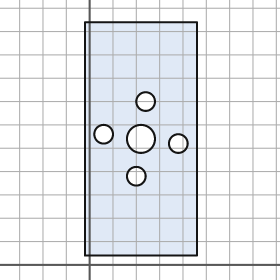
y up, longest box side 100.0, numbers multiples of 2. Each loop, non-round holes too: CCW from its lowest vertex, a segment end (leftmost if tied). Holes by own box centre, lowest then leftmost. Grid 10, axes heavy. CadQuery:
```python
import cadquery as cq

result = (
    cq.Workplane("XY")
    .moveTo(-2.0, 4.0)
    .lineTo(46.0, 4.0)
    .lineTo(46.0, 104.0)
    .lineTo(-2.0, 104.0)
    .close()
    .moveTo(20.0, 38.0)
    .circle(4.0)
    .moveTo(38.0, 52.0)
    .circle(4.0)
    .moveTo(22.0, 54.0)
    .circle(6.0)
    .moveTo(6.0, 56.0)
    .circle(4.0)
    .moveTo(24.0, 70.0)
    .circle(4.0)
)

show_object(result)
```